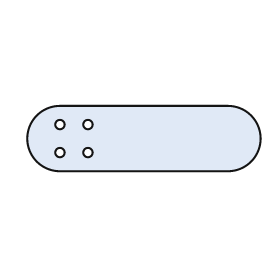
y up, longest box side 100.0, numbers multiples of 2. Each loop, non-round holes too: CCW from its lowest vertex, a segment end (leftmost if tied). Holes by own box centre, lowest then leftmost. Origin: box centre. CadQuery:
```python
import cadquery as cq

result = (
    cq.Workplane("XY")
    .moveTo(-36.0, -14.0)
    .lineTo(36.0, -14.0)
    .threePointArc((50.0, 0.0), (36.0, 14.0))
    .lineTo(-36.0, 14.0)
    .threePointArc((-50.0, 0.0), (-36.0, -14.0))
    .close()
    .moveTo(-36.0, -6.0)
    .circle(2.0)
    .moveTo(-24.0, -6.0)
    .circle(2.0)
    .moveTo(-36.0, 6.0)
    .circle(2.0)
    .moveTo(-24.0, 6.0)
    .circle(2.0)
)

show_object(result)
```